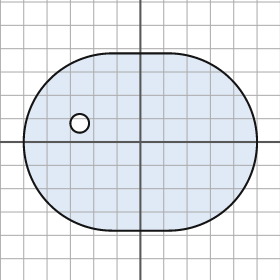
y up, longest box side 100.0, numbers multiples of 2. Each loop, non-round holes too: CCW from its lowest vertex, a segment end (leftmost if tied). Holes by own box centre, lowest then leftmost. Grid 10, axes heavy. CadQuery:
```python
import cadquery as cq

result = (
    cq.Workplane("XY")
    .moveTo(-12.0, -38.0)
    .lineTo(12.0, -38.0)
    .threePointArc((50.0, 0.0), (12.0, 38.0))
    .lineTo(-12.0, 38.0)
    .threePointArc((-50.0, 0.0), (-12.0, -38.0))
    .close()
    .moveTo(-26.0, 8.0)
    .circle(4.0)
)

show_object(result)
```